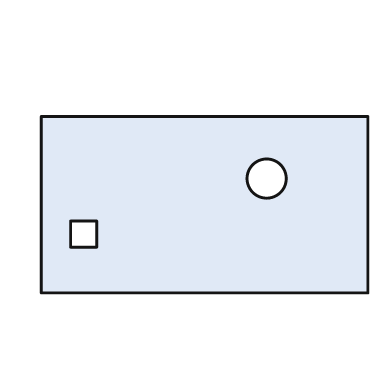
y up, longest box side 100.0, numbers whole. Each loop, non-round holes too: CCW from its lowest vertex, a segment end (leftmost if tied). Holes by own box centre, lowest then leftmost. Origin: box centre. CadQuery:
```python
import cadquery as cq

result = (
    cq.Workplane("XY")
    .moveTo(-50.0, -27.0)
    .lineTo(50.0, -27.0)
    .lineTo(50.0, 27.0)
    .lineTo(-50.0, 27.0)
    .close()
    .moveTo(-41.0, -13.0)
    .lineTo(-33.0, -13.0)
    .lineTo(-33.0, -5.0)
    .lineTo(-41.0, -5.0)
    .close()
    .moveTo(19.0, 8.0)
    .circle(6.0)
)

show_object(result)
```